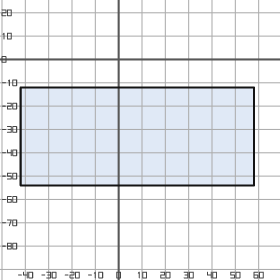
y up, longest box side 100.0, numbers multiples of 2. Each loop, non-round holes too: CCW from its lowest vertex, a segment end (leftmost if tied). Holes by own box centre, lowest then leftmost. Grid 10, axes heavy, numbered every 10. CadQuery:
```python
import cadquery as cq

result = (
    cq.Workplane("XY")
    .moveTo(-42.0, -54.0)
    .lineTo(58.0, -54.0)
    .lineTo(58.0, -12.0)
    .lineTo(-42.0, -12.0)
    .close()
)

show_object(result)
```